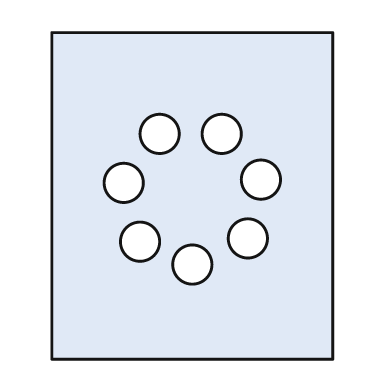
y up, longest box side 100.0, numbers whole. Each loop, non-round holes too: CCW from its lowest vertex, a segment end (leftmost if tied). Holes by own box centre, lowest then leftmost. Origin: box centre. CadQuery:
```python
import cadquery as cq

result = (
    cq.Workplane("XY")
    .moveTo(-43.0, -50.0)
    .lineTo(43.0, -50.0)
    .lineTo(43.0, 50.0)
    .lineTo(-43.0, 50.0)
    .close()
    .moveTo(0.0, -21.0)
    .circle(6.0)
    .moveTo(-16.0, -14.0)
    .circle(6.0)
    .moveTo(17.0, -13.0)
    .circle(6.0)
    .moveTo(-21.0, 4.0)
    .circle(6.0)
    .moveTo(21.0, 5.0)
    .circle(6.0)
    .moveTo(-10.0, 19.0)
    .circle(6.0)
    .moveTo(9.0, 19.0)
    .circle(6.0)
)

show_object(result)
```